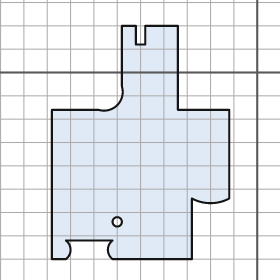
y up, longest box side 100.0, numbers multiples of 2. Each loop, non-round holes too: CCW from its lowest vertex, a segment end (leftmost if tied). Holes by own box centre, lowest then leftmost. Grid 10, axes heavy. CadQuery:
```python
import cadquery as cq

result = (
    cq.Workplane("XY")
    .moveTo(-88.0, -80.0)
    .lineTo(-82.0, -80.0)
    .threePointArc((-80.0, -76.0), (-82.0, -72.0))
    .lineTo(-62.0, -72.0)
    .threePointArc((-64.0, -76.0), (-62.0, -80.0))
    .lineTo(-28.0, -80.0)
    .lineTo(-28.0, -54.0)
    .threePointArc((-20.0, -56.0), (-12.0, -54.0))
    .lineTo(-12.0, -16.0)
    .lineTo(-34.0, -16.0)
    .lineTo(-34.0, 20.0)
    .lineTo(-48.0, 20.0)
    .lineTo(-48.0, 12.0)
    .lineTo(-52.0, 12.0)
    .lineTo(-52.0, 20.0)
    .lineTo(-58.0, 20.0)
    .lineTo(-58.0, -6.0)
    .threePointArc((-60.0, -14.0), (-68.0, -16.0))
    .lineTo(-88.0, -16.0)
    .close()
    .moveTo(-60.0, -64.0)
    .circle(2.0)
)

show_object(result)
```